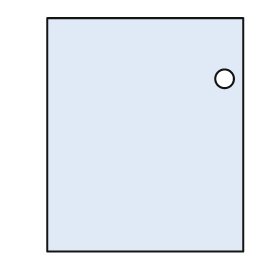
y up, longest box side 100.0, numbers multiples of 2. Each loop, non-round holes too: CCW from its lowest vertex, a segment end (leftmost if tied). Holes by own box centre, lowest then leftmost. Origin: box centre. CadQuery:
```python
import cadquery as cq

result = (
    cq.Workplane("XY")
    .moveTo(-42.0, -50.0)
    .lineTo(42.0, -50.0)
    .lineTo(42.0, 50.0)
    .lineTo(-42.0, 50.0)
    .close()
    .moveTo(34.0, 24.0)
    .circle(4.0)
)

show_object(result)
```